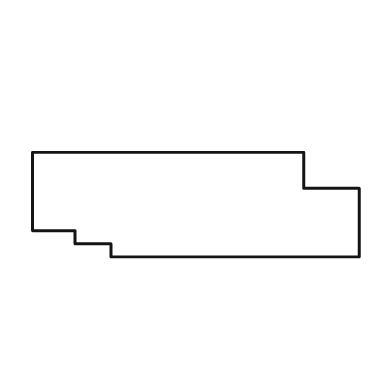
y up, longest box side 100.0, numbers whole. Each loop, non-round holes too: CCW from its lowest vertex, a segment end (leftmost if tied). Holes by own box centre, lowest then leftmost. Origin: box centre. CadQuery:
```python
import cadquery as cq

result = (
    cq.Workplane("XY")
    .moveTo(-26.0, -16.0)
    .lineTo(50.0, -16.0)
    .lineTo(50.0, 5.0)
    .lineTo(33.0, 5.0)
    .lineTo(33.0, 16.0)
    .lineTo(-50.0, 16.0)
    .lineTo(-50.0, -8.0)
    .lineTo(-37.0, -8.0)
    .lineTo(-37.0, -12.0)
    .lineTo(-26.0, -12.0)
    .close()
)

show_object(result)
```